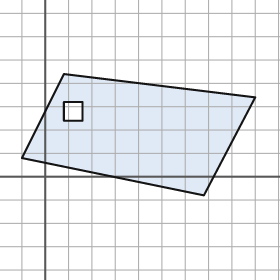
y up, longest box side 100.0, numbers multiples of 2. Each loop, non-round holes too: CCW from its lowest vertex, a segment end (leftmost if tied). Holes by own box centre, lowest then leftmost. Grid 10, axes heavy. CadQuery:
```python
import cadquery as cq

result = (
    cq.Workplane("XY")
    .moveTo(68.0, -8.0)
    .lineTo(90.0, 34.0)
    .lineTo(8.0, 44.0)
    .lineTo(-10.0, 8.0)
    .close()
    .moveTo(8.0, 24.0)
    .lineTo(16.0, 24.0)
    .lineTo(16.0, 32.0)
    .lineTo(8.0, 32.0)
    .close()
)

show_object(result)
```